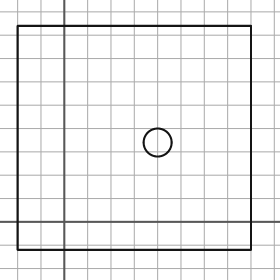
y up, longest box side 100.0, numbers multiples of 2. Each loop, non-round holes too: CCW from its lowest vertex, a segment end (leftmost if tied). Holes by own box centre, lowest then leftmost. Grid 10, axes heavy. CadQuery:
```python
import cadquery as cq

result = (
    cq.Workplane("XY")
    .moveTo(-20.0, -12.0)
    .lineTo(80.0, -12.0)
    .lineTo(80.0, 84.0)
    .lineTo(-20.0, 84.0)
    .close()
    .moveTo(40.0, 34.0)
    .circle(6.0)
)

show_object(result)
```